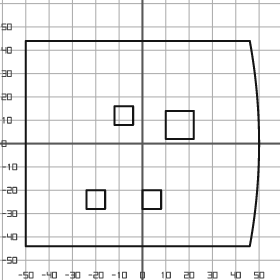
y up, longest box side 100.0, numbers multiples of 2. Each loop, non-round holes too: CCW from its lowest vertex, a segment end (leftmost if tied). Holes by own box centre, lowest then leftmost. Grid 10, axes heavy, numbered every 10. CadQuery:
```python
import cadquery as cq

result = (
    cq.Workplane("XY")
    .moveTo(-50.0, -44.0)
    .lineTo(46.0, -44.0)
    .threePointArc((50.0, 0.0), (46.0, 44.0))
    .lineTo(-50.0, 44.0)
    .close()
    .moveTo(-24.0, -28.0)
    .lineTo(-16.0, -28.0)
    .lineTo(-16.0, -20.0)
    .lineTo(-24.0, -20.0)
    .close()
    .moveTo(0.0, -28.0)
    .lineTo(8.0, -28.0)
    .lineTo(8.0, -20.0)
    .lineTo(0.0, -20.0)
    .close()
    .moveTo(10.0, 2.0)
    .lineTo(22.0, 2.0)
    .lineTo(22.0, 14.0)
    .lineTo(10.0, 14.0)
    .close()
    .moveTo(-12.0, 8.0)
    .lineTo(-4.0, 8.0)
    .lineTo(-4.0, 16.0)
    .lineTo(-12.0, 16.0)
    .close()
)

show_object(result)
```